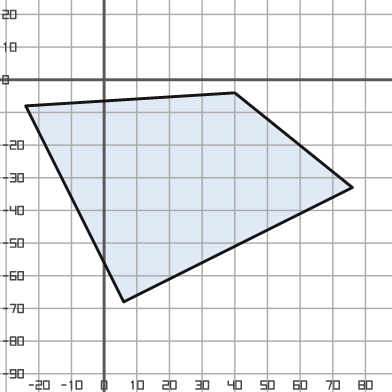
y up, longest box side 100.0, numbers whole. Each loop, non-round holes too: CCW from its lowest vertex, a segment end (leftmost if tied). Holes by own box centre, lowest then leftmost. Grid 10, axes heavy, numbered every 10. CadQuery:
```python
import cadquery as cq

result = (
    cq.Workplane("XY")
    .moveTo(6.0, -68.0)
    .lineTo(76.0, -33.0)
    .lineTo(40.0, -4.0)
    .lineTo(-24.0, -8.0)
    .close()
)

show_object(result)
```